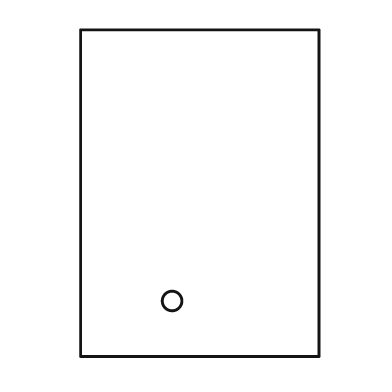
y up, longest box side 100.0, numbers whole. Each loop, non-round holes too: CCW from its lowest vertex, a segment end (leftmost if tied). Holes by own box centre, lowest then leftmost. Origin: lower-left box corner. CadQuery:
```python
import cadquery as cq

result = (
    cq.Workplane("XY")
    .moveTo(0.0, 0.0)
    .lineTo(73.0, 0.0)
    .lineTo(73.0, 100.0)
    .lineTo(0.0, 100.0)
    .close()
    .moveTo(28.0, 17.0)
    .circle(3.0)
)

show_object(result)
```